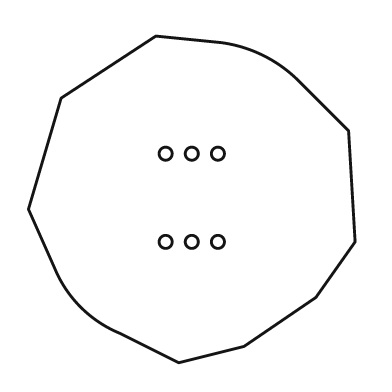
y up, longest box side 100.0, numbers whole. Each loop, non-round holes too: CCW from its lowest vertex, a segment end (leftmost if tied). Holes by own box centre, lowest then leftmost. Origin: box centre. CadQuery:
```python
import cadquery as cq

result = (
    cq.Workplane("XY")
    .moveTo(-4.0, -50.0)
    .lineTo(16.0, -45.0)
    .lineTo(38.0, -30.0)
    .lineTo(50.0, -13.0)
    .lineTo(48.0, 21.0)
    .lineTo(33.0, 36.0)
    .threePointArc((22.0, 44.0), (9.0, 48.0))
    .lineTo(-11.0, 50.0)
    .lineTo(-40.0, 31.0)
    .lineTo(-50.0, -3.0)
    .lineTo(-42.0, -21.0)
    .threePointArc((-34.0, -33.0), (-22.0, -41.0))
    .close()
    .moveTo(-8.0, -13.0)
    .circle(2.0)
    .moveTo(0.0, -13.0)
    .circle(2.0)
    .moveTo(8.0, -13.0)
    .circle(2.0)
    .moveTo(-8.0, 14.0)
    .circle(2.0)
    .moveTo(0.0, 14.0)
    .circle(2.0)
    .moveTo(8.0, 14.0)
    .circle(2.0)
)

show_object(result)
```